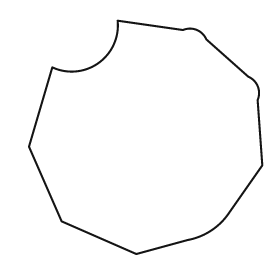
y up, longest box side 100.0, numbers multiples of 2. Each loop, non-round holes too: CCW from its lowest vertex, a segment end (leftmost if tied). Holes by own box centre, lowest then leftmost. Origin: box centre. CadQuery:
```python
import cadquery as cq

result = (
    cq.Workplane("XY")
    .moveTo(-4.0, -50.0)
    .lineTo(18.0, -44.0)
    .threePointArc((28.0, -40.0), (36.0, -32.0))
    .lineTo(50.0, -12.0)
    .lineTo(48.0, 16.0)
    .threePointArc((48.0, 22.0), (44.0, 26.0))
    .lineTo(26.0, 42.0)
    .threePointArc((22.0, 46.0), (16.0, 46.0))
    .lineTo(-12.0, 50.0)
    .threePointArc((-20.0, 32.0), (-40.0, 30.0))
    .lineTo(-50.0, -4.0)
    .lineTo(-36.0, -36.0)
    .close()
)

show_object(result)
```